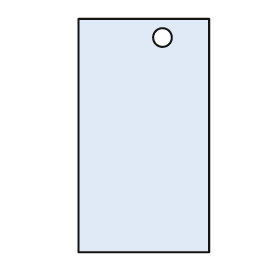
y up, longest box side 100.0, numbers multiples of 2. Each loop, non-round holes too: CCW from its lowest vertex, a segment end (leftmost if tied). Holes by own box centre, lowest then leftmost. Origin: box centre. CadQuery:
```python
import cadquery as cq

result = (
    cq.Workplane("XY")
    .moveTo(-28.0, -50.0)
    .lineTo(28.0, -50.0)
    .lineTo(28.0, 50.0)
    .lineTo(-28.0, 50.0)
    .close()
    .moveTo(8.0, 42.0)
    .circle(4.0)
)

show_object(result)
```